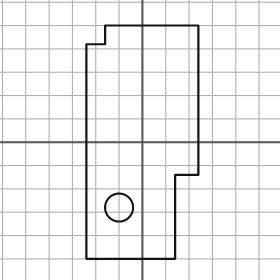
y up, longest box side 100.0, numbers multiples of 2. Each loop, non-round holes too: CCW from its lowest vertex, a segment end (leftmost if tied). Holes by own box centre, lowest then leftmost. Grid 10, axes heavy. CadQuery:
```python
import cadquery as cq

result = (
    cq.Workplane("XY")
    .moveTo(-24.0, -50.0)
    .lineTo(14.0, -50.0)
    .lineTo(14.0, -14.0)
    .lineTo(24.0, -14.0)
    .lineTo(24.0, 50.0)
    .lineTo(-16.0, 50.0)
    .lineTo(-16.0, 42.0)
    .lineTo(-24.0, 42.0)
    .close()
    .moveTo(-10.0, -28.0)
    .circle(6.0)
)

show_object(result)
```